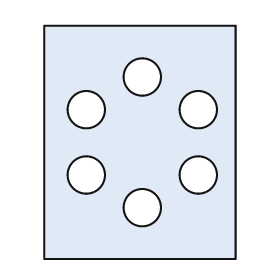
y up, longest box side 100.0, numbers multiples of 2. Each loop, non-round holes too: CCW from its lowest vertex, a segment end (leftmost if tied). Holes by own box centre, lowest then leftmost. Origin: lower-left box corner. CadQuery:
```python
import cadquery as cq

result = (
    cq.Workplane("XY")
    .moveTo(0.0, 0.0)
    .lineTo(82.0, 0.0)
    .lineTo(82.0, 100.0)
    .lineTo(0.0, 100.0)
    .close()
    .moveTo(42.0, 22.0)
    .circle(8.0)
    .moveTo(18.0, 36.0)
    .circle(8.0)
    .moveTo(66.0, 36.0)
    .circle(8.0)
    .moveTo(18.0, 64.0)
    .circle(8.0)
    .moveTo(66.0, 64.0)
    .circle(8.0)
    .moveTo(42.0, 78.0)
    .circle(8.0)
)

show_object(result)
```